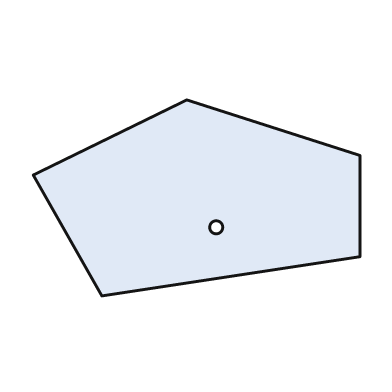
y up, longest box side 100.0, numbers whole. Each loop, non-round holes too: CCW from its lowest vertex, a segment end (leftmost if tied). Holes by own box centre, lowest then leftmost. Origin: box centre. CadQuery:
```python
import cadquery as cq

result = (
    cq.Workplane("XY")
    .moveTo(-29.0, -30.0)
    .lineTo(50.0, -18.0)
    .lineTo(50.0, 13.0)
    .lineTo(-3.0, 30.0)
    .lineTo(-50.0, 7.0)
    .close()
    .moveTo(6.0, -9.0)
    .circle(2.0)
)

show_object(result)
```